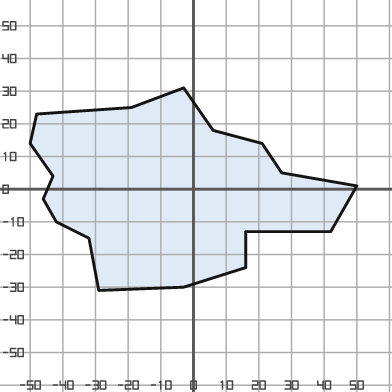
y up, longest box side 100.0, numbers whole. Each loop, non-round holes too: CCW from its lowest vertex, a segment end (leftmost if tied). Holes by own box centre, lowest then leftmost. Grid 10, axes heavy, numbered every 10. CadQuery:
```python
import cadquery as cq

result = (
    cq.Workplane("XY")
    .moveTo(-29.0, -31.0)
    .lineTo(-3.0, -30.0)
    .lineTo(16.0, -24.0)
    .lineTo(16.0, -13.0)
    .lineTo(42.0, -13.0)
    .lineTo(50.0, 1.0)
    .lineTo(27.0, 5.0)
    .lineTo(21.0, 14.0)
    .lineTo(6.0, 18.0)
    .lineTo(-3.0, 31.0)
    .lineTo(-19.0, 25.0)
    .lineTo(-48.0, 23.0)
    .lineTo(-50.0, 14.0)
    .lineTo(-43.0, 4.0)
    .lineTo(-46.0, -3.0)
    .lineTo(-42.0, -10.0)
    .lineTo(-32.0, -15.0)
    .close()
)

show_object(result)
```